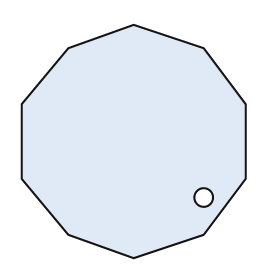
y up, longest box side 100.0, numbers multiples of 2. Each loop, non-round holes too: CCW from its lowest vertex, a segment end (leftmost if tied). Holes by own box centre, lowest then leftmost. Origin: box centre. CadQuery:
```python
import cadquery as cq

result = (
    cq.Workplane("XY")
    .moveTo(0.0, -50.0)
    .lineTo(30.0, -40.0)
    .lineTo(48.0, -16.0)
    .lineTo(48.0, 16.0)
    .lineTo(30.0, 40.0)
    .lineTo(0.0, 50.0)
    .lineTo(-28.0, 40.0)
    .lineTo(-48.0, 16.0)
    .lineTo(-48.0, -16.0)
    .lineTo(-28.0, -40.0)
    .close()
    .moveTo(30.0, -24.0)
    .circle(4.0)
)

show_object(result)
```